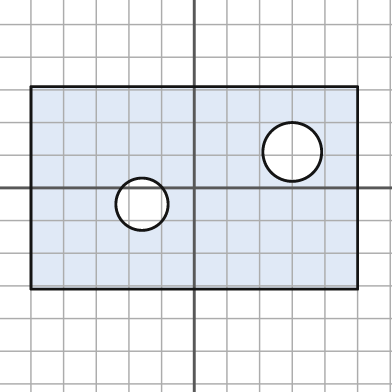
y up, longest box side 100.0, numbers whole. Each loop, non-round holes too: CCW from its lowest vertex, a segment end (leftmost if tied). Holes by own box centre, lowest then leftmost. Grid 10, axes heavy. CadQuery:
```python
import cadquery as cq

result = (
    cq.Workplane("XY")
    .moveTo(-50.0, -31.0)
    .lineTo(50.0, -31.0)
    .lineTo(50.0, 31.0)
    .lineTo(-50.0, 31.0)
    .close()
    .moveTo(-16.0, -5.0)
    .circle(8.0)
    .moveTo(30.0, 11.0)
    .circle(9.0)
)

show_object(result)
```